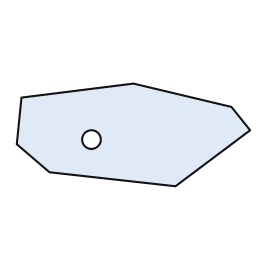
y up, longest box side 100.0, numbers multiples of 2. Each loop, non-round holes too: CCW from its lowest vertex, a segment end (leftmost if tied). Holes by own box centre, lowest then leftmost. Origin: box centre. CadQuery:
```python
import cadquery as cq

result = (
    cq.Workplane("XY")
    .moveTo(18.0, -22.0)
    .lineTo(50.0, 2.0)
    .lineTo(42.0, 12.0)
    .lineTo(0.0, 22.0)
    .lineTo(-48.0, 16.0)
    .lineTo(-50.0, -4.0)
    .lineTo(-36.0, -16.0)
    .close()
    .moveTo(-18.0, -2.0)
    .circle(4.0)
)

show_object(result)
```